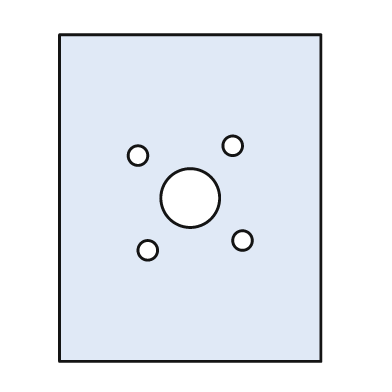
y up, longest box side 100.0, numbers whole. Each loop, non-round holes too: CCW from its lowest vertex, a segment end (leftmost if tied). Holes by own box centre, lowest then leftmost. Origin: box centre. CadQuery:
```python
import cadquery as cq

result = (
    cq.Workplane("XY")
    .moveTo(-40.0, -50.0)
    .lineTo(40.0, -50.0)
    .lineTo(40.0, 50.0)
    .lineTo(-40.0, 50.0)
    .close()
    .moveTo(-13.0, -16.0)
    .circle(3.0)
    .moveTo(16.0, -13.0)
    .circle(3.0)
    .moveTo(0.0, 0.0)
    .circle(9.0)
    .moveTo(-16.0, 13.0)
    .circle(3.0)
    .moveTo(13.0, 16.0)
    .circle(3.0)
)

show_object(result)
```